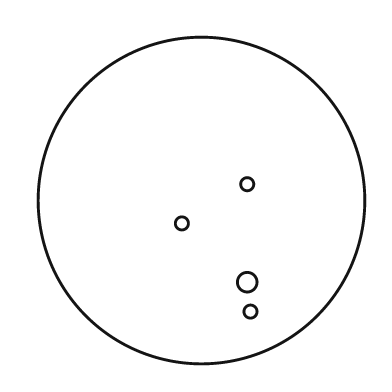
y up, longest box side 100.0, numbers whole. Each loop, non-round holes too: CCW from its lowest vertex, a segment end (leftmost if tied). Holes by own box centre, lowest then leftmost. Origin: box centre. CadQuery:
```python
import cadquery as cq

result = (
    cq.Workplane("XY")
    .moveTo(0.0, 0.0)
    .circle(50.0)
    .moveTo(15.0, -34.0)
    .circle(2.0)
    .moveTo(14.0, -25.0)
    .circle(3.0)
    .moveTo(-6.0, -7.0)
    .circle(2.0)
    .moveTo(14.0, 5.0)
    .circle(2.0)
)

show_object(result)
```